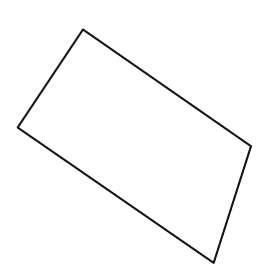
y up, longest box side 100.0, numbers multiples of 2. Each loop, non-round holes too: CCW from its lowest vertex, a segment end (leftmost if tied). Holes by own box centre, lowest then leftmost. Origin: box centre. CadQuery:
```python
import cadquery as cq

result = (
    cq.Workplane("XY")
    .moveTo(34.0, -50.0)
    .lineTo(50.0, 0.0)
    .lineTo(-22.0, 50.0)
    .lineTo(-50.0, 8.0)
    .close()
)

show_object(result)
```